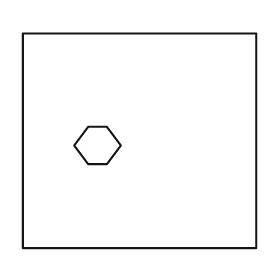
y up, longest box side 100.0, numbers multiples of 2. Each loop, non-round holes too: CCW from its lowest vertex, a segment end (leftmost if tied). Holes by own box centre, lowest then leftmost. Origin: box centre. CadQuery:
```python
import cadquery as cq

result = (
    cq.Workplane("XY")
    .moveTo(-50.0, -46.0)
    .lineTo(50.0, -46.0)
    .lineTo(50.0, 46.0)
    .lineTo(-50.0, 46.0)
    .close()
    .moveTo(-22.0, -10.0)
    .lineTo(-14.0, -10.0)
    .lineTo(-8.0, -2.0)
    .lineTo(-14.0, 6.0)
    .lineTo(-22.0, 6.0)
    .lineTo(-28.0, -2.0)
    .close()
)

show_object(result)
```